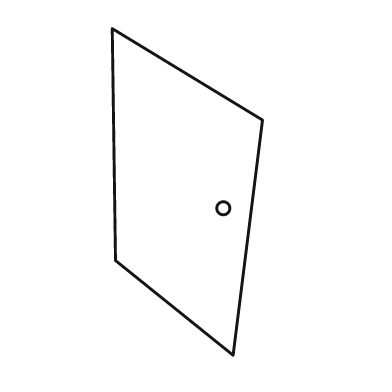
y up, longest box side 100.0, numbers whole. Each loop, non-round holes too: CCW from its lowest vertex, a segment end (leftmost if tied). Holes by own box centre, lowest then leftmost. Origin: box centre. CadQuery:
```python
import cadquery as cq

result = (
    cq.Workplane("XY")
    .moveTo(14.0, -50.0)
    .lineTo(23.0, 22.0)
    .lineTo(-23.0, 50.0)
    .lineTo(-22.0, -21.0)
    .close()
    .moveTo(11.0, -5.0)
    .circle(2.0)
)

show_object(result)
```